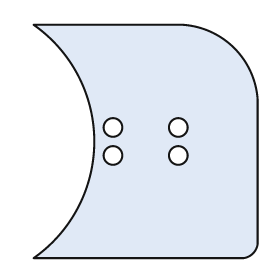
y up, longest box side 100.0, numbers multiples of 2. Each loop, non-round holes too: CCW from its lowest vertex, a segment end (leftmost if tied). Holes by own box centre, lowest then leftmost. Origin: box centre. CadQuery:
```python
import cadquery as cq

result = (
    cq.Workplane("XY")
    .moveTo(-48.0, -50.0)
    .lineTo(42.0, -50.0)
    .threePointArc((46.0, -48.0), (48.0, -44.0))
    .lineTo(48.0, 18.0)
    .threePointArc((38.0, 40.0), (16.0, 50.0))
    .lineTo(-48.0, 50.0)
    .threePointArc((-22.0, 0.0), (-48.0, -50.0))
    .close()
    .moveTo(-14.0, -6.0)
    .circle(4.0)
    .moveTo(14.0, -6.0)
    .circle(4.0)
    .moveTo(-14.0, 6.0)
    .circle(4.0)
    .moveTo(14.0, 6.0)
    .circle(4.0)
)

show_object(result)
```